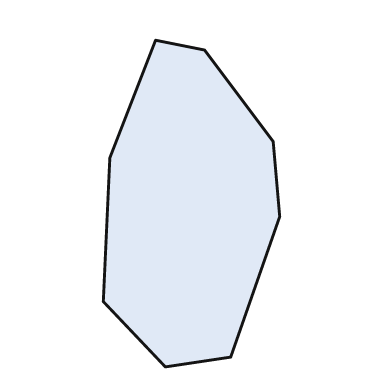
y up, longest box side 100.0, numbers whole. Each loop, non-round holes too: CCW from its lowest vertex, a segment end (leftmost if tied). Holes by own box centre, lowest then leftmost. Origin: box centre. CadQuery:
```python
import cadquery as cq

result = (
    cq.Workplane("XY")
    .moveTo(-8.0, -50.0)
    .lineTo(12.0, -47.0)
    .lineTo(27.0, -4.0)
    .lineTo(25.0, 19.0)
    .lineTo(4.0, 47.0)
    .lineTo(-11.0, 50.0)
    .lineTo(-25.0, 14.0)
    .lineTo(-27.0, -30.0)
    .close()
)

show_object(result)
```